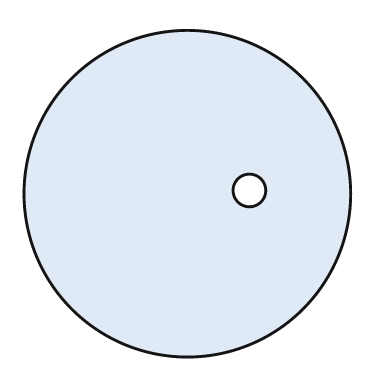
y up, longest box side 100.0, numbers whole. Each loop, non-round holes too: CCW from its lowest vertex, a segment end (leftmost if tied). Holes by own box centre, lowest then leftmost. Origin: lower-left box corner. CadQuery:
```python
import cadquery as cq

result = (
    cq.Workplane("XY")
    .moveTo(50.0, 50.0)
    .circle(50.0)
    .moveTo(69.0, 51.0)
    .circle(5.0)
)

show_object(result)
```